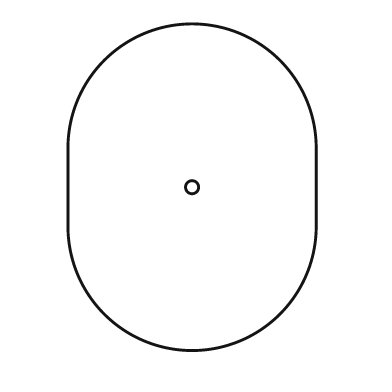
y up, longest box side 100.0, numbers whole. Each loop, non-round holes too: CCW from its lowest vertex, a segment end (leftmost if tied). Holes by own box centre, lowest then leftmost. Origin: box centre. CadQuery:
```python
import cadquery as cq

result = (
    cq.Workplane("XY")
    .moveTo(-38.0, -12.0)
    .threePointArc((0.0, -50.0), (38.0, -12.0))
    .lineTo(38.0, 12.0)
    .threePointArc((0.0, 50.0), (-38.0, 12.0))
    .close()
    .moveTo(0.0, 0.0)
    .circle(2.0)
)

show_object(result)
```